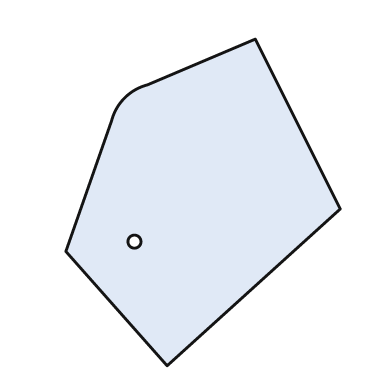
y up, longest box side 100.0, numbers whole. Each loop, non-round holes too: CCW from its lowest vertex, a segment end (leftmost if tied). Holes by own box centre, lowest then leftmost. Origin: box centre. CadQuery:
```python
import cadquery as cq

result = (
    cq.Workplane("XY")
    .moveTo(-11.0, -50.0)
    .lineTo(42.0, -2.0)
    .lineTo(16.0, 50.0)
    .lineTo(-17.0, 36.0)
    .threePointArc((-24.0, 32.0), (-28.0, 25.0))
    .lineTo(-42.0, -15.0)
    .close()
    .moveTo(-21.0, -12.0)
    .circle(2.0)
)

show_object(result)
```